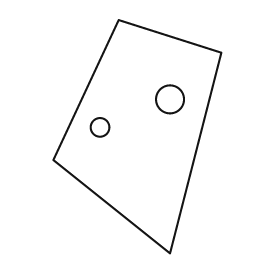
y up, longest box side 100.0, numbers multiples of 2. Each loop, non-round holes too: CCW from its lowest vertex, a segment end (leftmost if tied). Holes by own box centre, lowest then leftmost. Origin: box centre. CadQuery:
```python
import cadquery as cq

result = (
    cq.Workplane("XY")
    .moveTo(14.0, -50.0)
    .lineTo(36.0, 36.0)
    .lineTo(-8.0, 50.0)
    .lineTo(-36.0, -10.0)
    .close()
    .moveTo(-16.0, 4.0)
    .circle(4.0)
    .moveTo(14.0, 16.0)
    .circle(6.0)
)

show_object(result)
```